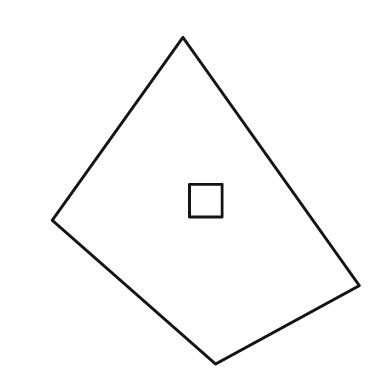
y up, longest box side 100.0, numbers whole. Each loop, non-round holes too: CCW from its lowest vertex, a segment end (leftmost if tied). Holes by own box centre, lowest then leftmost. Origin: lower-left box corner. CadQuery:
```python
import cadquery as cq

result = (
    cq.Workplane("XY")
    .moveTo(50.0, 0.0)
    .lineTo(94.0, 24.0)
    .lineTo(40.0, 100.0)
    .lineTo(0.0, 44.0)
    .close()
    .moveTo(42.0, 45.0)
    .lineTo(52.0, 45.0)
    .lineTo(52.0, 55.0)
    .lineTo(42.0, 55.0)
    .close()
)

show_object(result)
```